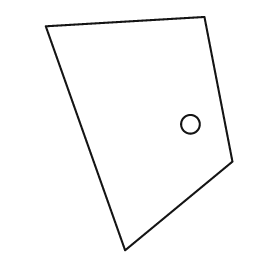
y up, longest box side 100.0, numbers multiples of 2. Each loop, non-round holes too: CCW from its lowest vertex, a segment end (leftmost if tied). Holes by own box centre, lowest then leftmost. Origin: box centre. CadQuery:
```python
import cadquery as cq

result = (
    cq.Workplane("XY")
    .moveTo(-6.0, -50.0)
    .lineTo(40.0, -12.0)
    .lineTo(28.0, 50.0)
    .lineTo(-40.0, 46.0)
    .close()
    .moveTo(22.0, 4.0)
    .circle(4.0)
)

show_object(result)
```